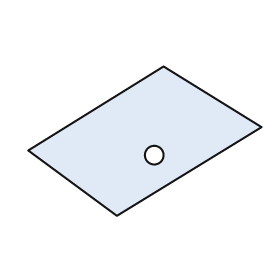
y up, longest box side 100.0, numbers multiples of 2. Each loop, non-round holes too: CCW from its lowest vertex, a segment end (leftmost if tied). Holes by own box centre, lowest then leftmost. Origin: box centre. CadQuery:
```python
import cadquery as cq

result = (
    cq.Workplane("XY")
    .moveTo(-12.0, -32.0)
    .lineTo(50.0, 6.0)
    .lineTo(8.0, 32.0)
    .lineTo(-50.0, -4.0)
    .close()
    .moveTo(4.0, -6.0)
    .circle(4.0)
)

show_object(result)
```